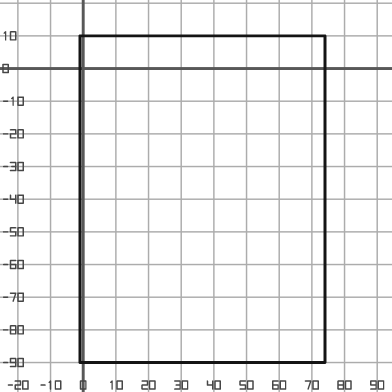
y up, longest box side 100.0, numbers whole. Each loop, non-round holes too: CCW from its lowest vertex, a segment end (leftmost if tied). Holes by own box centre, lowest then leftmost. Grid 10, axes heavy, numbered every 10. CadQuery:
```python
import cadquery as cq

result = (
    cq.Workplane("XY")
    .moveTo(-1.0, -90.0)
    .lineTo(74.0, -90.0)
    .lineTo(74.0, 10.0)
    .lineTo(-1.0, 10.0)
    .close()
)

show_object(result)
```